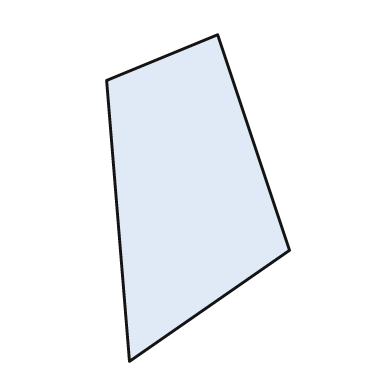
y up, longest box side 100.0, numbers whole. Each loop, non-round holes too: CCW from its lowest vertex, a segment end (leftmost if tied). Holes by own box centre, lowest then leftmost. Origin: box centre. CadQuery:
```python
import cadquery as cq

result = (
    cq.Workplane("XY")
    .moveTo(-21.0, -50.0)
    .lineTo(28.0, -16.0)
    .lineTo(6.0, 50.0)
    .lineTo(-28.0, 36.0)
    .close()
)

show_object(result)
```